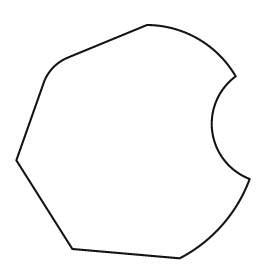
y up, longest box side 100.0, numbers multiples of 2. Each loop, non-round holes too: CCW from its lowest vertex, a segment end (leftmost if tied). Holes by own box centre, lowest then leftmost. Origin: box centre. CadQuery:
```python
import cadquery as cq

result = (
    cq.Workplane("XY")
    .moveTo(20.0, -50.0)
    .threePointArc((38.0, -36.0), (50.0, -16.0))
    .threePointArc((34.0, 4.0), (44.0, 28.0))
    .threePointArc((28.0, 44.0), (6.0, 50.0))
    .lineTo(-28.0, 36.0)
    .threePointArc((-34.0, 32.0), (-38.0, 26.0))
    .lineTo(-50.0, -8.0)
    .lineTo(-26.0, -46.0)
    .close()
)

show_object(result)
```